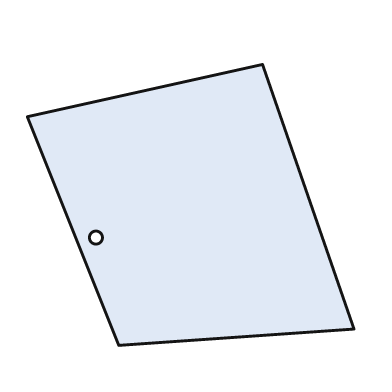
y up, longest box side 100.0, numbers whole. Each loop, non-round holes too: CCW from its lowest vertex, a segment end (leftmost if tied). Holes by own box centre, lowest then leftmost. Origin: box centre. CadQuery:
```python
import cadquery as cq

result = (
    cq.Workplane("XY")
    .moveTo(-22.0, -43.0)
    .lineTo(50.0, -38.0)
    .lineTo(22.0, 43.0)
    .lineTo(-50.0, 27.0)
    .close()
    .moveTo(-29.0, -10.0)
    .circle(2.0)
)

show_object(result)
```